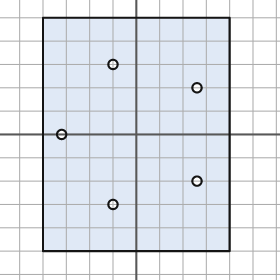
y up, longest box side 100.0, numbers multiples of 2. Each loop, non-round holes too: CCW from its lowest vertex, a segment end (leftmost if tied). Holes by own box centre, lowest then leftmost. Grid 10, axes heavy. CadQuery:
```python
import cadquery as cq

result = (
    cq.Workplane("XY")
    .moveTo(-40.0, -50.0)
    .lineTo(40.0, -50.0)
    .lineTo(40.0, 50.0)
    .lineTo(-40.0, 50.0)
    .close()
    .moveTo(-10.0, -30.0)
    .circle(2.0)
    .moveTo(26.0, -20.0)
    .circle(2.0)
    .moveTo(-32.0, 0.0)
    .circle(2.0)
    .moveTo(26.0, 20.0)
    .circle(2.0)
    .moveTo(-10.0, 30.0)
    .circle(2.0)
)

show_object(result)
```